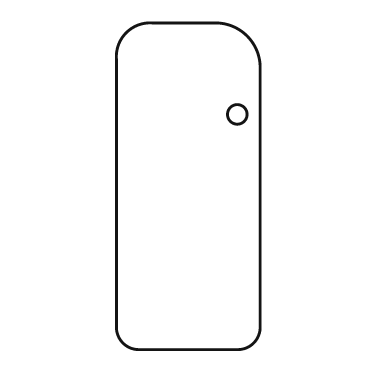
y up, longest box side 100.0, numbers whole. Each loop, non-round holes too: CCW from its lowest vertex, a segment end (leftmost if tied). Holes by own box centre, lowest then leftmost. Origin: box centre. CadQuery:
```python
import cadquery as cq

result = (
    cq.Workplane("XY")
    .moveTo(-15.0, -50.0)
    .lineTo(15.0, -50.0)
    .threePointArc((20.0, -48.0), (22.0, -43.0))
    .lineTo(22.0, 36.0)
    .threePointArc((18.0, 46.0), (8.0, 50.0))
    .lineTo(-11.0, 50.0)
    .threePointArc((-19.0, 47.0), (-22.0, 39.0))
    .lineTo(-22.0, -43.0)
    .threePointArc((-20.0, -48.0), (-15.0, -50.0))
    .close()
    .moveTo(15.0, 22.0)
    .circle(3.0)
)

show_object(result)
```